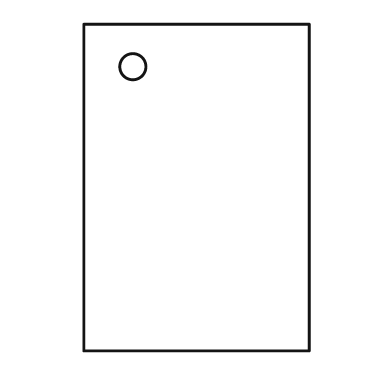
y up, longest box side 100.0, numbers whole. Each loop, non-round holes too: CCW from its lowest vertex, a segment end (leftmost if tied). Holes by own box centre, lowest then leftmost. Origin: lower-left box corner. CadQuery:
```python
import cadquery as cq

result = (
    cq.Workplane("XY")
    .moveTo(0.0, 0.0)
    .lineTo(69.0, 0.0)
    .lineTo(69.0, 100.0)
    .lineTo(0.0, 100.0)
    .close()
    .moveTo(15.0, 87.0)
    .circle(4.0)
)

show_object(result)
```